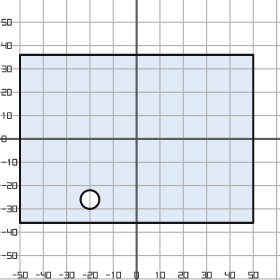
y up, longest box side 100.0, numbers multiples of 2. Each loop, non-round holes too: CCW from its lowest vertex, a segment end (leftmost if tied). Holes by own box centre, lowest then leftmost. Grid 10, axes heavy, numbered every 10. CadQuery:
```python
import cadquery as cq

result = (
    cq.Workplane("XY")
    .moveTo(-50.0, -36.0)
    .lineTo(50.0, -36.0)
    .lineTo(50.0, 36.0)
    .lineTo(-50.0, 36.0)
    .close()
    .moveTo(-20.0, -26.0)
    .circle(4.0)
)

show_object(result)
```